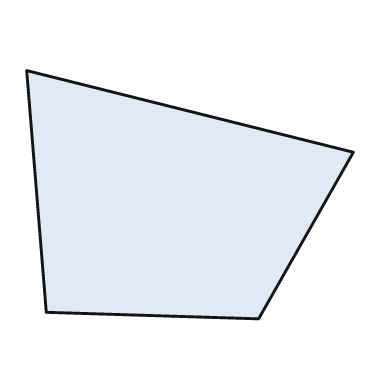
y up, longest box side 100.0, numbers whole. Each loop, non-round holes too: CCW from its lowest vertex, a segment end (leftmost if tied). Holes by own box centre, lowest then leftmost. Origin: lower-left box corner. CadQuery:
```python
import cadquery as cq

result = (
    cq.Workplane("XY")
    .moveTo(71.0, 0.0)
    .lineTo(100.0, 51.0)
    .lineTo(0.0, 76.0)
    .lineTo(6.0, 2.0)
    .close()
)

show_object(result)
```